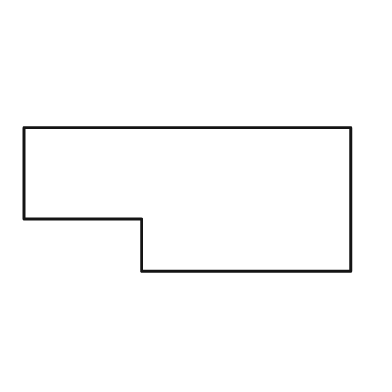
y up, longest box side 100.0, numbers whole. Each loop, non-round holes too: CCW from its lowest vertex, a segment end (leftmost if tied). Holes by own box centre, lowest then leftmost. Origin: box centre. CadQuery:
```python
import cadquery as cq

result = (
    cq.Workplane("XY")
    .moveTo(-14.0, -22.0)
    .lineTo(50.0, -22.0)
    .lineTo(50.0, 22.0)
    .lineTo(-50.0, 22.0)
    .lineTo(-50.0, -6.0)
    .lineTo(-14.0, -6.0)
    .close()
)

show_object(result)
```